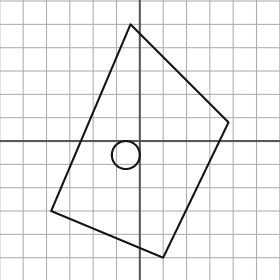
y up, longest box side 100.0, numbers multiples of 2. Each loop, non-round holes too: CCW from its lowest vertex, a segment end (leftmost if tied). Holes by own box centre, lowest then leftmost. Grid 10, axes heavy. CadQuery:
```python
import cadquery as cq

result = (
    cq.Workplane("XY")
    .moveTo(10.0, -50.0)
    .lineTo(38.0, 8.0)
    .lineTo(-4.0, 50.0)
    .lineTo(-38.0, -30.0)
    .close()
    .moveTo(-6.0, -6.0)
    .circle(6.0)
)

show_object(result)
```